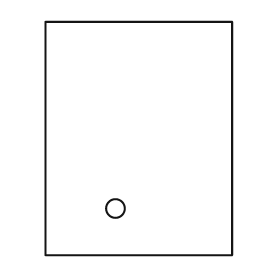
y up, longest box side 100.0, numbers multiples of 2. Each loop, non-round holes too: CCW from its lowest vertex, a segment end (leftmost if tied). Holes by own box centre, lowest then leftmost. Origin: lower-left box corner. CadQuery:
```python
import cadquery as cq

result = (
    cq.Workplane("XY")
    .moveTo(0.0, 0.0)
    .lineTo(80.0, 0.0)
    .lineTo(80.0, 100.0)
    .lineTo(0.0, 100.0)
    .close()
    .moveTo(30.0, 20.0)
    .circle(4.0)
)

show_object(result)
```